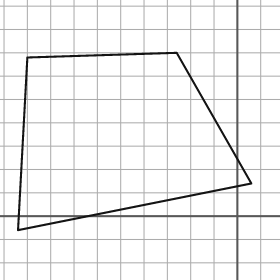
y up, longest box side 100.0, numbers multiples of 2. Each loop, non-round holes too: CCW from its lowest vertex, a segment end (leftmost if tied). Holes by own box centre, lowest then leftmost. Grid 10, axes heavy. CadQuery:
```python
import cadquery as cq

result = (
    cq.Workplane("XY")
    .moveTo(-94.0, -6.0)
    .lineTo(6.0, 14.0)
    .lineTo(-26.0, 70.0)
    .lineTo(-90.0, 68.0)
    .close()
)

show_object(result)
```